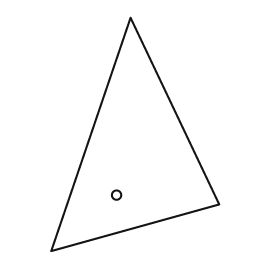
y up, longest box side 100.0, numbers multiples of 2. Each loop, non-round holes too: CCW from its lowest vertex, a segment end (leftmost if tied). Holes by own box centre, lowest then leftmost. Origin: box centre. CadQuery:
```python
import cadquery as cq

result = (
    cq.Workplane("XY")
    .moveTo(-36.0, -50.0)
    .lineTo(36.0, -30.0)
    .lineTo(-2.0, 50.0)
    .close()
    .moveTo(-8.0, -26.0)
    .circle(2.0)
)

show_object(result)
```